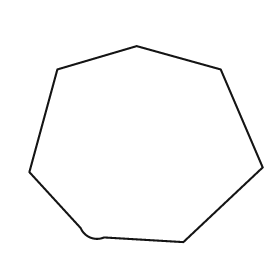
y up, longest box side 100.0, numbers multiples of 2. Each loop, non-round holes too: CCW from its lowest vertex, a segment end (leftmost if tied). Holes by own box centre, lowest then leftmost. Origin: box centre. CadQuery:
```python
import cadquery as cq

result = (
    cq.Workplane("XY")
    .moveTo(16.0, -42.0)
    .lineTo(50.0, -10.0)
    .lineTo(32.0, 32.0)
    .lineTo(-4.0, 42.0)
    .lineTo(-38.0, 32.0)
    .lineTo(-50.0, -12.0)
    .lineTo(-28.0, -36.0)
    .threePointArc((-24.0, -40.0), (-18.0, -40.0))
    .close()
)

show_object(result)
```